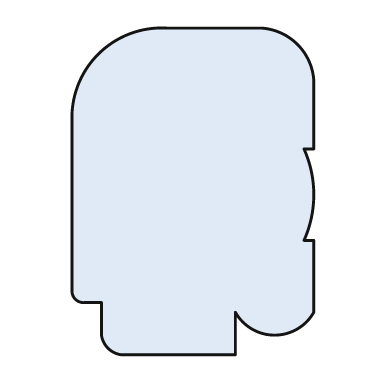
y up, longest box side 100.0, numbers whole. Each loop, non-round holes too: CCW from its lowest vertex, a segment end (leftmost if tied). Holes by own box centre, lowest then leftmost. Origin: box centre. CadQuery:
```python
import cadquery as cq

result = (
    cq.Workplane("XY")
    .moveTo(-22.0, -50.0)
    .lineTo(13.0, -50.0)
    .lineTo(13.0, -37.0)
    .threePointArc((25.0, -44.0), (37.0, -37.0))
    .lineTo(37.0, -15.0)
    .lineTo(34.0, -15.0)
    .threePointArc((37.0, -1.0), (34.0, 13.0))
    .lineTo(37.0, 13.0)
    .lineTo(37.0, 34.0)
    .threePointArc((32.0, 45.0), (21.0, 50.0))
    .lineTo(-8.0, 50.0)
    .threePointArc((-29.0, 42.0), (-37.0, 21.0))
    .lineTo(-37.0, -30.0)
    .threePointArc((-36.0, -33.0), (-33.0, -34.0))
    .lineTo(-28.0, -34.0)
    .lineTo(-28.0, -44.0)
    .threePointArc((-26.0, -48.0), (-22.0, -50.0))
    .close()
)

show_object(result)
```